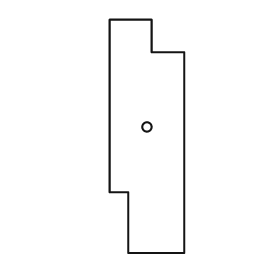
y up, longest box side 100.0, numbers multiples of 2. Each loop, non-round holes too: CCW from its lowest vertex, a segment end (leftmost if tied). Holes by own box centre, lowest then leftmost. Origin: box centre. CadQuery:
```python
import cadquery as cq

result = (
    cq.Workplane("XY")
    .moveTo(-8.0, -50.0)
    .lineTo(16.0, -50.0)
    .lineTo(16.0, 36.0)
    .lineTo(2.0, 36.0)
    .lineTo(2.0, 50.0)
    .lineTo(-16.0, 50.0)
    .lineTo(-16.0, -24.0)
    .lineTo(-8.0, -24.0)
    .close()
    .moveTo(0.0, 4.0)
    .circle(2.0)
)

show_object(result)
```